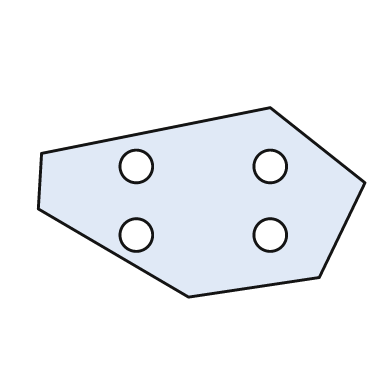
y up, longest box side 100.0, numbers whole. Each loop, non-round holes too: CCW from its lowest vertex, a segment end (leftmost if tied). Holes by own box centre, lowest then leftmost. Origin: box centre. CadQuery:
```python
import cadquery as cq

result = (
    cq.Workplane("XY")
    .moveTo(-4.0, -29.0)
    .lineTo(36.0, -23.0)
    .lineTo(50.0, 6.0)
    .lineTo(21.0, 29.0)
    .lineTo(-49.0, 15.0)
    .lineTo(-50.0, -2.0)
    .close()
    .moveTo(-20.0, -10.0)
    .circle(5.0)
    .moveTo(21.0, -10.0)
    .circle(5.0)
    .moveTo(-20.0, 11.0)
    .circle(5.0)
    .moveTo(21.0, 11.0)
    .circle(5.0)
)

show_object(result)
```